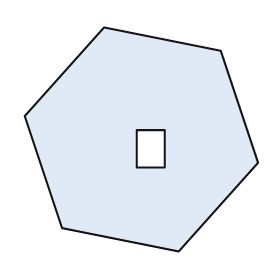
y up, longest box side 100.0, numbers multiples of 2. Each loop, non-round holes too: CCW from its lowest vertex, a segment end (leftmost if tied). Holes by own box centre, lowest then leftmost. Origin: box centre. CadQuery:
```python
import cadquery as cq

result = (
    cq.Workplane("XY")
    .moveTo(16.0, -48.0)
    .lineTo(50.0, -10.0)
    .lineTo(34.0, 38.0)
    .lineTo(-16.0, 48.0)
    .lineTo(-50.0, 10.0)
    .lineTo(-34.0, -38.0)
    .close()
    .moveTo(-2.0, -12.0)
    .lineTo(10.0, -12.0)
    .lineTo(10.0, 4.0)
    .lineTo(-2.0, 4.0)
    .close()
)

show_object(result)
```